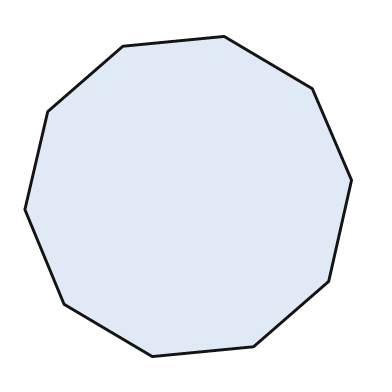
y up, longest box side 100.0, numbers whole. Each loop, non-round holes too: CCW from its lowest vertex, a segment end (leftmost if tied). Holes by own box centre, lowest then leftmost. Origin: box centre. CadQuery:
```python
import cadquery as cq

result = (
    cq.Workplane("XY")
    .moveTo(-11.0, -49.0)
    .lineTo(20.0, -46.0)
    .lineTo(43.0, -26.0)
    .lineTo(50.0, 5.0)
    .lineTo(38.0, 33.0)
    .lineTo(11.0, 49.0)
    .lineTo(-20.0, 46.0)
    .lineTo(-43.0, 26.0)
    .lineTo(-50.0, -4.0)
    .lineTo(-38.0, -33.0)
    .close()
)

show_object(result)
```